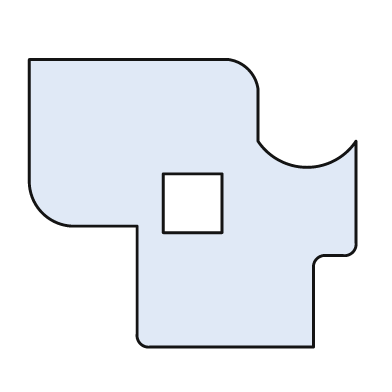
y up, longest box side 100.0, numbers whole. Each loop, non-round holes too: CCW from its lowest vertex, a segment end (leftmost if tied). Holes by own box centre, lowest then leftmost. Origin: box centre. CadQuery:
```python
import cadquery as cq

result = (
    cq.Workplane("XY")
    .moveTo(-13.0, -44.0)
    .lineTo(37.0, -44.0)
    .lineTo(37.0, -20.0)
    .threePointArc((38.0, -17.0), (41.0, -16.0))
    .lineTo(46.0, -16.0)
    .threePointArc((49.0, -15.0), (50.0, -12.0))
    .lineTo(50.0, 19.0)
    .threePointArc((35.0, 11.0), (20.0, 19.0))
    .lineTo(20.0, 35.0)
    .threePointArc((17.0, 41.0), (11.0, 44.0))
    .lineTo(-50.0, 44.0)
    .lineTo(-50.0, 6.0)
    .threePointArc((-46.0, -3.0), (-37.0, -7.0))
    .lineTo(-17.0, -7.0)
    .lineTo(-17.0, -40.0)
    .threePointArc((-16.0, -43.0), (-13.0, -44.0))
    .close()
    .moveTo(-9.0, -9.0)
    .lineTo(9.0, -9.0)
    .lineTo(9.0, 9.0)
    .lineTo(-9.0, 9.0)
    .close()
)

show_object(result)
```